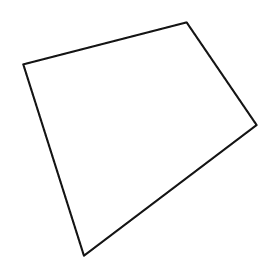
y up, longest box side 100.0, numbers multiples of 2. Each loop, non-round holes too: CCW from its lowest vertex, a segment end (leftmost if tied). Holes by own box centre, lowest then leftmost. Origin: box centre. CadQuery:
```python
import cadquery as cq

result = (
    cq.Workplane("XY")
    .moveTo(-24.0, -50.0)
    .lineTo(50.0, 6.0)
    .lineTo(20.0, 50.0)
    .lineTo(-50.0, 32.0)
    .close()
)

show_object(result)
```